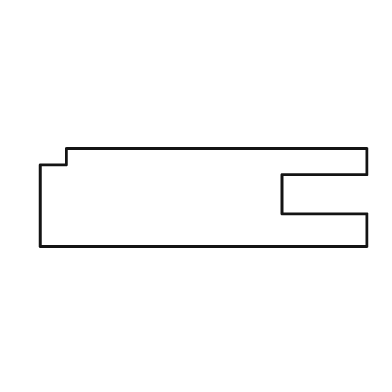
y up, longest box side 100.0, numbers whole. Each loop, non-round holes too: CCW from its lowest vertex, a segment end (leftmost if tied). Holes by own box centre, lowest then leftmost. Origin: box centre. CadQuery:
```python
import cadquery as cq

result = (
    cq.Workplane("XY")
    .moveTo(-50.0, -15.0)
    .lineTo(50.0, -15.0)
    .lineTo(50.0, -5.0)
    .lineTo(24.0, -5.0)
    .lineTo(24.0, 7.0)
    .lineTo(50.0, 7.0)
    .lineTo(50.0, 15.0)
    .lineTo(-42.0, 15.0)
    .lineTo(-42.0, 10.0)
    .lineTo(-50.0, 10.0)
    .close()
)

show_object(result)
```